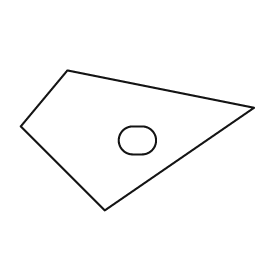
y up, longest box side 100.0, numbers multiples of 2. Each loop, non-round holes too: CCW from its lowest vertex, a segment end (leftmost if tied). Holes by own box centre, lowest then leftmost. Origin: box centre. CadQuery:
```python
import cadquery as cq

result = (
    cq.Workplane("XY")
    .moveTo(-14.0, -30.0)
    .lineTo(50.0, 14.0)
    .lineTo(-30.0, 30.0)
    .lineTo(-50.0, 6.0)
    .close()
    .moveTo(-2.0, -6.0)
    .lineTo(2.0, -6.0)
    .threePointArc((8.0, 0.0), (2.0, 6.0))
    .lineTo(-2.0, 6.0)
    .threePointArc((-8.0, 0.0), (-2.0, -6.0))
    .close()
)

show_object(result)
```